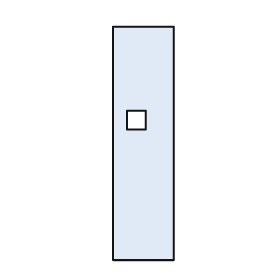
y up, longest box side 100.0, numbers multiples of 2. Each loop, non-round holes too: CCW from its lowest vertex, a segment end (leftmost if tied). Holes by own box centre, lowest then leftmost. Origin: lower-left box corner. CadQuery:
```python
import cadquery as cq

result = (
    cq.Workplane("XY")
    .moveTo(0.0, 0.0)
    .lineTo(26.0, 0.0)
    .lineTo(26.0, 100.0)
    .lineTo(0.0, 100.0)
    .close()
    .moveTo(6.0, 56.0)
    .lineTo(14.0, 56.0)
    .lineTo(14.0, 64.0)
    .lineTo(6.0, 64.0)
    .close()
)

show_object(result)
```